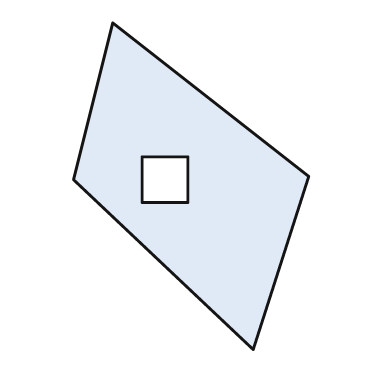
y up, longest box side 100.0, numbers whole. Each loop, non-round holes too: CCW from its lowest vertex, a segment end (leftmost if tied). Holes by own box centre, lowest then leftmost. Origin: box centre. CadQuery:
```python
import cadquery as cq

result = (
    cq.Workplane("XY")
    .moveTo(19.0, -50.0)
    .lineTo(36.0, 3.0)
    .lineTo(-24.0, 50.0)
    .lineTo(-36.0, 2.0)
    .close()
    .moveTo(-15.0, -5.0)
    .lineTo(-1.0, -5.0)
    .lineTo(-1.0, 9.0)
    .lineTo(-15.0, 9.0)
    .close()
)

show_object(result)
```